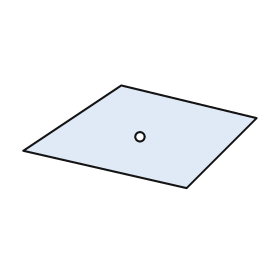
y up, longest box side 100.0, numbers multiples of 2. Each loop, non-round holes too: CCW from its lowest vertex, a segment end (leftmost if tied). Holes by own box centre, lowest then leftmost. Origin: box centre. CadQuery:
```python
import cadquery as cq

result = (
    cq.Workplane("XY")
    .moveTo(20.0, -22.0)
    .lineTo(50.0, 8.0)
    .lineTo(-8.0, 22.0)
    .lineTo(-50.0, -6.0)
    .close()
    .moveTo(0.0, 0.0)
    .circle(2.0)
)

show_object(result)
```